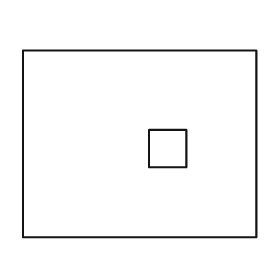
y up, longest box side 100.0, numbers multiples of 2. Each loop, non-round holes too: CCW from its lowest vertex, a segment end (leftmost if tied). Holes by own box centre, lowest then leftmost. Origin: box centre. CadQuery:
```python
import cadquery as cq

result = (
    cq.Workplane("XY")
    .moveTo(-50.0, -40.0)
    .lineTo(50.0, -40.0)
    .lineTo(50.0, 40.0)
    .lineTo(-50.0, 40.0)
    .close()
    .moveTo(4.0, -10.0)
    .lineTo(20.0, -10.0)
    .lineTo(20.0, 6.0)
    .lineTo(4.0, 6.0)
    .close()
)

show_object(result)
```